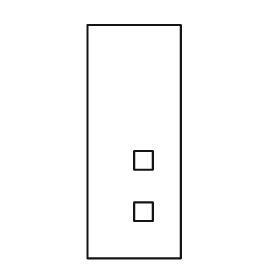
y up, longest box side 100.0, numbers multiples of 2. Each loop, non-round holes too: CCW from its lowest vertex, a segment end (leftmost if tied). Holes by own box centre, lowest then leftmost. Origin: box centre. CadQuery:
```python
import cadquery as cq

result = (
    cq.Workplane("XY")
    .moveTo(-20.0, -50.0)
    .lineTo(20.0, -50.0)
    .lineTo(20.0, 50.0)
    .lineTo(-20.0, 50.0)
    .close()
    .moveTo(0.0, -34.0)
    .lineTo(8.0, -34.0)
    .lineTo(8.0, -26.0)
    .lineTo(0.0, -26.0)
    .close()
    .moveTo(0.0, -12.0)
    .lineTo(8.0, -12.0)
    .lineTo(8.0, -4.0)
    .lineTo(0.0, -4.0)
    .close()
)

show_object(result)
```